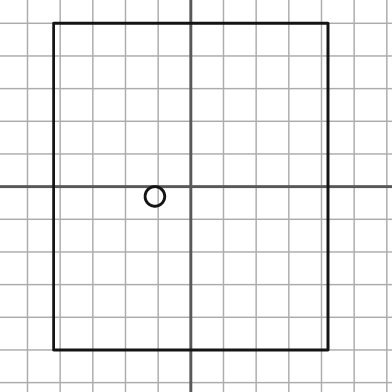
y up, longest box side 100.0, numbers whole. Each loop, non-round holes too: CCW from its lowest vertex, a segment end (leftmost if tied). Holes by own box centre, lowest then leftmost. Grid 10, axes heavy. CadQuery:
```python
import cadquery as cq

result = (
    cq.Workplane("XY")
    .moveTo(-42.0, -50.0)
    .lineTo(42.0, -50.0)
    .lineTo(42.0, 50.0)
    .lineTo(-42.0, 50.0)
    .close()
    .moveTo(-11.0, -3.0)
    .circle(3.0)
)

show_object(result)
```